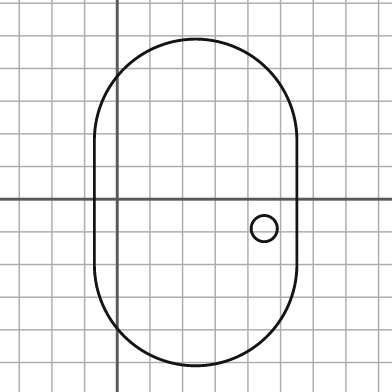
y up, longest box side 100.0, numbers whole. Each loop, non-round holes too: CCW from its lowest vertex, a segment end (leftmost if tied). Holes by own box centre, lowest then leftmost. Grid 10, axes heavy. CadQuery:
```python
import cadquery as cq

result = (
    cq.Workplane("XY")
    .moveTo(-7.0, -20.0)
    .threePointArc((24.0, -51.0), (55.0, -20.0))
    .lineTo(55.0, 18.0)
    .threePointArc((24.0, 49.0), (-7.0, 18.0))
    .close()
    .moveTo(45.0, -9.0)
    .circle(4.0)
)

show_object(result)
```